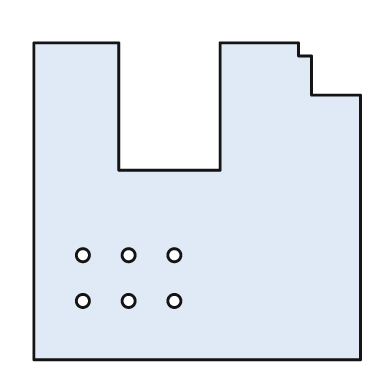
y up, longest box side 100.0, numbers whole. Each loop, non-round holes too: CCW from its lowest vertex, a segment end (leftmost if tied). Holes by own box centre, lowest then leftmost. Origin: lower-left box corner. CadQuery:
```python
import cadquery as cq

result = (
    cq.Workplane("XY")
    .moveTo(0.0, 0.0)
    .lineTo(100.0, 0.0)
    .lineTo(100.0, 81.0)
    .lineTo(85.0, 81.0)
    .lineTo(85.0, 93.0)
    .lineTo(81.0, 93.0)
    .lineTo(81.0, 97.0)
    .lineTo(57.0, 97.0)
    .lineTo(57.0, 58.0)
    .lineTo(26.0, 58.0)
    .lineTo(26.0, 97.0)
    .lineTo(0.0, 97.0)
    .close()
    .moveTo(15.0, 18.0)
    .circle(2.0)
    .moveTo(29.0, 18.0)
    .circle(2.0)
    .moveTo(43.0, 18.0)
    .circle(2.0)
    .moveTo(15.0, 32.0)
    .circle(2.0)
    .moveTo(29.0, 32.0)
    .circle(2.0)
    .moveTo(43.0, 32.0)
    .circle(2.0)
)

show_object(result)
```